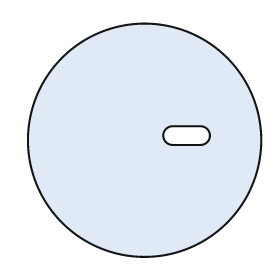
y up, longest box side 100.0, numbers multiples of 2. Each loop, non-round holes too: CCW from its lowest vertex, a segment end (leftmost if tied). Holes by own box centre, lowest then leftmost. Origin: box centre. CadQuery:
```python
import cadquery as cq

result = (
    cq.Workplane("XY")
    .moveTo(0.0, 0.0)
    .circle(50.0)
    .moveTo(12.0, -2.0)
    .lineTo(24.0, -2.0)
    .threePointArc((28.0, 2.0), (24.0, 6.0))
    .lineTo(12.0, 6.0)
    .threePointArc((8.0, 2.0), (12.0, -2.0))
    .close()
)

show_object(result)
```